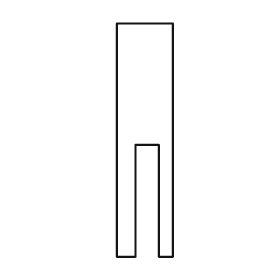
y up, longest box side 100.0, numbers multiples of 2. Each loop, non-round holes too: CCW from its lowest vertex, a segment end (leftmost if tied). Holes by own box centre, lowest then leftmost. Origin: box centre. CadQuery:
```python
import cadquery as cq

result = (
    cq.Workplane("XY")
    .moveTo(-12.0, -50.0)
    .lineTo(-4.0, -50.0)
    .lineTo(-4.0, -2.0)
    .lineTo(6.0, -2.0)
    .lineTo(6.0, -50.0)
    .lineTo(12.0, -50.0)
    .lineTo(12.0, 50.0)
    .lineTo(-12.0, 50.0)
    .close()
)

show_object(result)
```